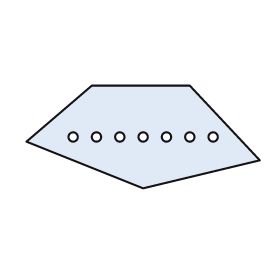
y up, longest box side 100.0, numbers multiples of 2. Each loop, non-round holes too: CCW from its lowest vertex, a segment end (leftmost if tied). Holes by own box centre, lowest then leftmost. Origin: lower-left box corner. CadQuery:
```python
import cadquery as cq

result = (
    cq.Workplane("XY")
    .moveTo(50.0, 0.0)
    .lineTo(100.0, 12.0)
    .lineTo(70.0, 44.0)
    .lineTo(28.0, 44.0)
    .lineTo(0.0, 20.0)
    .close()
    .moveTo(20.0, 22.0)
    .circle(2.0)
    .moveTo(30.0, 22.0)
    .circle(2.0)
    .moveTo(40.0, 22.0)
    .circle(2.0)
    .moveTo(50.0, 22.0)
    .circle(2.0)
    .moveTo(60.0, 22.0)
    .circle(2.0)
    .moveTo(70.0, 22.0)
    .circle(2.0)
    .moveTo(80.0, 22.0)
    .circle(2.0)
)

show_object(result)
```